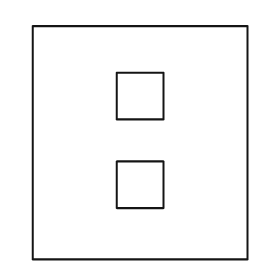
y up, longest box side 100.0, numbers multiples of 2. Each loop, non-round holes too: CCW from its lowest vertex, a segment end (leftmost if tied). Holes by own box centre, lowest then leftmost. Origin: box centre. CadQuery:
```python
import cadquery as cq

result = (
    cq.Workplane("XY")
    .moveTo(-46.0, -50.0)
    .lineTo(46.0, -50.0)
    .lineTo(46.0, 50.0)
    .lineTo(-46.0, 50.0)
    .close()
    .moveTo(-10.0, -28.0)
    .lineTo(10.0, -28.0)
    .lineTo(10.0, -8.0)
    .lineTo(-10.0, -8.0)
    .close()
    .moveTo(-10.0, 10.0)
    .lineTo(10.0, 10.0)
    .lineTo(10.0, 30.0)
    .lineTo(-10.0, 30.0)
    .close()
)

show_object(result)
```